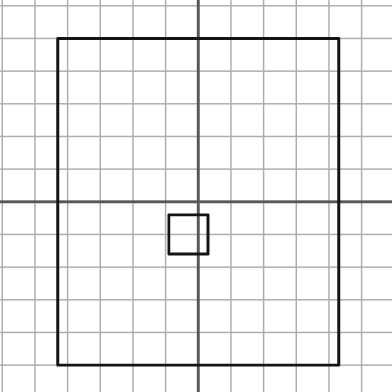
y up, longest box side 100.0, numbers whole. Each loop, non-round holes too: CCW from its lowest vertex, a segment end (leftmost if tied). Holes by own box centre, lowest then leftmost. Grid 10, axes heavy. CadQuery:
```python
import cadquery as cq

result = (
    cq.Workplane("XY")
    .moveTo(-43.0, -50.0)
    .lineTo(43.0, -50.0)
    .lineTo(43.0, 50.0)
    .lineTo(-43.0, 50.0)
    .close()
    .moveTo(-9.0, -16.0)
    .lineTo(3.0, -16.0)
    .lineTo(3.0, -4.0)
    .lineTo(-9.0, -4.0)
    .close()
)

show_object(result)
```